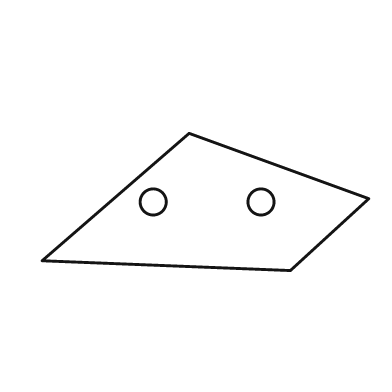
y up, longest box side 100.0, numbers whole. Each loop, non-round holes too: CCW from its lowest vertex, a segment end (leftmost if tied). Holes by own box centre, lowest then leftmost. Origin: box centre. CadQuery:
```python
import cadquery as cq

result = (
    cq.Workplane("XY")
    .moveTo(26.0, -21.0)
    .lineTo(50.0, 1.0)
    .lineTo(-5.0, 21.0)
    .lineTo(-50.0, -18.0)
    .close()
    .moveTo(-16.0, 0.0)
    .circle(4.0)
    .moveTo(17.0, 0.0)
    .circle(4.0)
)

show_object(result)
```